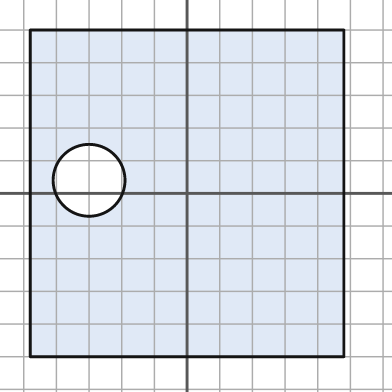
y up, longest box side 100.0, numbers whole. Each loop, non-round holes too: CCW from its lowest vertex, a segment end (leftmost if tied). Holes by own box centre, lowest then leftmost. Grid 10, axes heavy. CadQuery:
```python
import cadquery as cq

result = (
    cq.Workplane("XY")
    .moveTo(-48.0, -50.0)
    .lineTo(48.0, -50.0)
    .lineTo(48.0, 50.0)
    .lineTo(-48.0, 50.0)
    .close()
    .moveTo(-30.0, 4.0)
    .circle(11.0)
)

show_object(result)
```